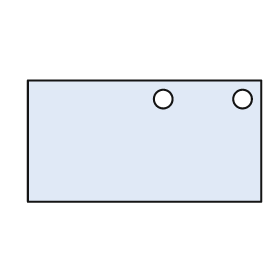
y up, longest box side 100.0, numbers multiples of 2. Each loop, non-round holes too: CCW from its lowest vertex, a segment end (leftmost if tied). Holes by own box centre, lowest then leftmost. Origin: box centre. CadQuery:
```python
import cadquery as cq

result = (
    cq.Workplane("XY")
    .moveTo(-50.0, -26.0)
    .lineTo(50.0, -26.0)
    .lineTo(50.0, 26.0)
    .lineTo(-50.0, 26.0)
    .close()
    .moveTo(8.0, 18.0)
    .circle(4.0)
    .moveTo(42.0, 18.0)
    .circle(4.0)
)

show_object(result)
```